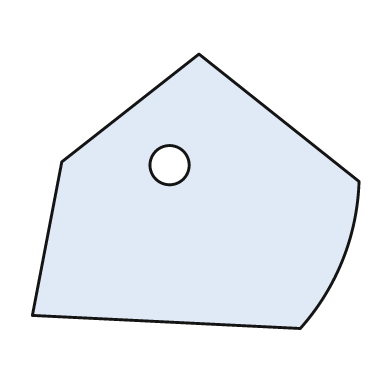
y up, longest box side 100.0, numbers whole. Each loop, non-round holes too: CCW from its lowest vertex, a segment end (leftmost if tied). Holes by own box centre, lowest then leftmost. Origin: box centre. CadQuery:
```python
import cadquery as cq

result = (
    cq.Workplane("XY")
    .moveTo(32.0, -42.0)
    .threePointArc((45.0, -21.0), (50.0, 3.0))
    .lineTo(1.0, 42.0)
    .lineTo(-41.0, 9.0)
    .lineTo(-50.0, -38.0)
    .close()
    .moveTo(-8.0, 8.0)
    .circle(6.0)
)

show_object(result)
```